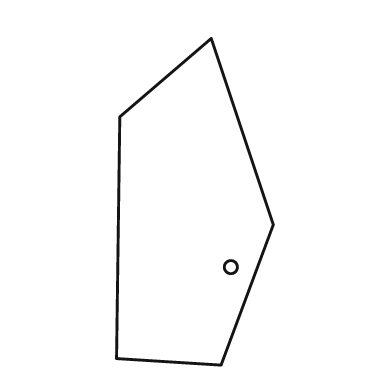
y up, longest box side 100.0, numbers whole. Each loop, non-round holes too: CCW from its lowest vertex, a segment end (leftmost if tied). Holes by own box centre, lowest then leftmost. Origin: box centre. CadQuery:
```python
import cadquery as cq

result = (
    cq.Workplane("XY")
    .moveTo(8.0, -50.0)
    .lineTo(24.0, -7.0)
    .lineTo(5.0, 50.0)
    .lineTo(-23.0, 26.0)
    .lineTo(-24.0, -48.0)
    .close()
    .moveTo(11.0, -20.0)
    .circle(2.0)
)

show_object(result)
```